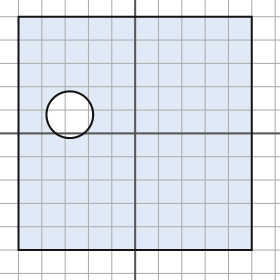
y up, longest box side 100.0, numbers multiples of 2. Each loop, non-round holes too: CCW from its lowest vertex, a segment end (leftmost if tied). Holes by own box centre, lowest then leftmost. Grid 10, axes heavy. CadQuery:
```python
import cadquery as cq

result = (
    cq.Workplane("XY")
    .moveTo(-50.0, -50.0)
    .lineTo(50.0, -50.0)
    .lineTo(50.0, 50.0)
    .lineTo(-50.0, 50.0)
    .close()
    .moveTo(-28.0, 8.0)
    .circle(10.0)
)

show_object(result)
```